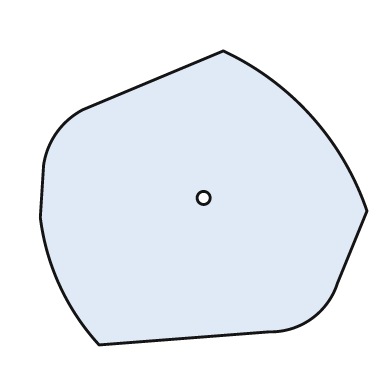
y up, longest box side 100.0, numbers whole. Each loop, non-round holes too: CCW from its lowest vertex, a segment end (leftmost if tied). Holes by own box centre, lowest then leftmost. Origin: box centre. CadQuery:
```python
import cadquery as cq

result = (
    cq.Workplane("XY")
    .moveTo(-32.0, -45.0)
    .lineTo(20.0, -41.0)
    .threePointArc((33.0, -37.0), (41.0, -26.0))
    .lineTo(50.0, -4.0)
    .threePointArc((33.0, 25.0), (6.0, 45.0))
    .lineTo(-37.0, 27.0)
    .threePointArc((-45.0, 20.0), (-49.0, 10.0))
    .lineTo(-50.0, -6.0)
    .threePointArc((-44.0, -27.0), (-32.0, -45.0))
    .close()
    .moveTo(0.0, 0.0)
    .circle(2.0)
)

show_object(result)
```